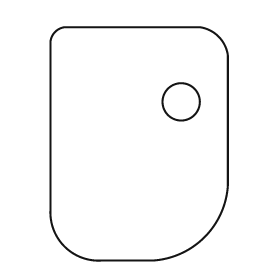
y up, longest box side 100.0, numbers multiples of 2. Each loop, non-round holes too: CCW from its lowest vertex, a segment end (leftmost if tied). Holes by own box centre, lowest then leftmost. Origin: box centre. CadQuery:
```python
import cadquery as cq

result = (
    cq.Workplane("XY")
    .moveTo(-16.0, -50.0)
    .lineTo(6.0, -50.0)
    .threePointArc((28.0, -40.0), (38.0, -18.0))
    .lineTo(38.0, 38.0)
    .threePointArc((34.0, 46.0), (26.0, 50.0))
    .lineTo(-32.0, 50.0)
    .threePointArc((-36.0, 48.0), (-38.0, 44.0))
    .lineTo(-38.0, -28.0)
    .threePointArc((-32.0, -44.0), (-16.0, -50.0))
    .close()
    .moveTo(18.0, 18.0)
    .circle(8.0)
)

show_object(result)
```